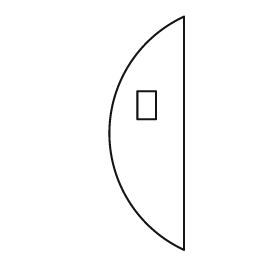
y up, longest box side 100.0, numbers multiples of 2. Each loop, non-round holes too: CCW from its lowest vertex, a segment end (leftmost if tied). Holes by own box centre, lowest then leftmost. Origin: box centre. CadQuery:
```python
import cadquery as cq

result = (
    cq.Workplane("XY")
    .moveTo(16.0, -50.0)
    .lineTo(16.0, 50.0)
    .threePointArc((-16.0, 0.0), (16.0, -50.0))
    .close()
    .moveTo(-4.0, 6.0)
    .lineTo(4.0, 6.0)
    .lineTo(4.0, 18.0)
    .lineTo(-4.0, 18.0)
    .close()
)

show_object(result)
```